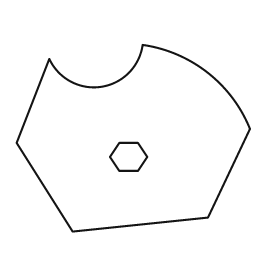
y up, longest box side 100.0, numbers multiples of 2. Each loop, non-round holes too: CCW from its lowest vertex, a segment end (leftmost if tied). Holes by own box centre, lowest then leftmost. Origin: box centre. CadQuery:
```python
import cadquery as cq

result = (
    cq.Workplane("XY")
    .moveTo(-26.0, -40.0)
    .lineTo(32.0, -34.0)
    .lineTo(50.0, 4.0)
    .threePointArc((32.0, 28.0), (4.0, 40.0))
    .threePointArc((-14.0, 22.0), (-36.0, 34.0))
    .lineTo(-50.0, -2.0)
    .close()
    .moveTo(-6.0, -14.0)
    .lineTo(2.0, -14.0)
    .lineTo(6.0, -8.0)
    .lineTo(2.0, -2.0)
    .lineTo(-6.0, -2.0)
    .lineTo(-10.0, -8.0)
    .close()
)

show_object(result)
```